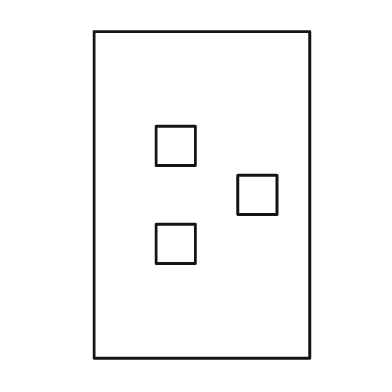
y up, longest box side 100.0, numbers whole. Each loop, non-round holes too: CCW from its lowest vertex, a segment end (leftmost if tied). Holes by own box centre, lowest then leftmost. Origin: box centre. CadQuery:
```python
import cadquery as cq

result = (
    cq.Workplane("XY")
    .moveTo(-33.0, -50.0)
    .lineTo(33.0, -50.0)
    .lineTo(33.0, 50.0)
    .lineTo(-33.0, 50.0)
    .close()
    .moveTo(-14.0, -21.0)
    .lineTo(-2.0, -21.0)
    .lineTo(-2.0, -9.0)
    .lineTo(-14.0, -9.0)
    .close()
    .moveTo(11.0, -6.0)
    .lineTo(23.0, -6.0)
    .lineTo(23.0, 6.0)
    .lineTo(11.0, 6.0)
    .close()
    .moveTo(-14.0, 9.0)
    .lineTo(-2.0, 9.0)
    .lineTo(-2.0, 21.0)
    .lineTo(-14.0, 21.0)
    .close()
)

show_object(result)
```